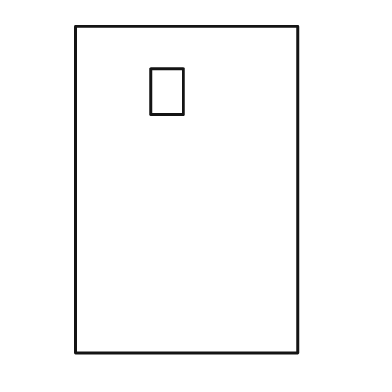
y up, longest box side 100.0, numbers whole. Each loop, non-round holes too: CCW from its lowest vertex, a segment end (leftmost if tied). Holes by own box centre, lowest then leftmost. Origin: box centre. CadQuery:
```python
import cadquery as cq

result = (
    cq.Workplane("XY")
    .moveTo(-34.0, -50.0)
    .lineTo(34.0, -50.0)
    .lineTo(34.0, 50.0)
    .lineTo(-34.0, 50.0)
    .close()
    .moveTo(-11.0, 23.0)
    .lineTo(-1.0, 23.0)
    .lineTo(-1.0, 37.0)
    .lineTo(-11.0, 37.0)
    .close()
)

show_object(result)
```